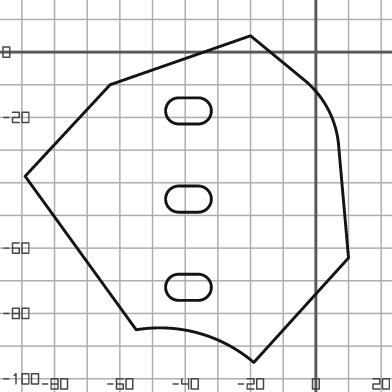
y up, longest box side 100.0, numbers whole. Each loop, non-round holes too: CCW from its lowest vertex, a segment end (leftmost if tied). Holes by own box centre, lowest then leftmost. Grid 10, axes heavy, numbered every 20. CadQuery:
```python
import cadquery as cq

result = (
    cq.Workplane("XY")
    .moveTo(-19.0, -95.0)
    .lineTo(10.0, -63.0)
    .lineTo(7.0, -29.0)
    .threePointArc((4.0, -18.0), (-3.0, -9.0))
    .lineTo(-20.0, 5.0)
    .lineTo(-63.0, -10.0)
    .lineTo(-89.0, -38.0)
    .lineTo(-55.0, -85.0)
    .threePointArc((-36.0, -86.0), (-19.0, -95.0))
    .close()
    .moveTo(-42.0, -76.0)
    .lineTo(-36.0, -76.0)
    .threePointArc((-32.0, -72.0), (-36.0, -68.0))
    .lineTo(-42.0, -68.0)
    .threePointArc((-46.0, -72.0), (-42.0, -76.0))
    .close()
    .moveTo(-42.0, -49.0)
    .lineTo(-36.0, -49.0)
    .threePointArc((-32.0, -45.0), (-36.0, -41.0))
    .lineTo(-42.0, -41.0)
    .threePointArc((-46.0, -45.0), (-42.0, -49.0))
    .close()
    .moveTo(-42.0, -22.0)
    .lineTo(-36.0, -22.0)
    .threePointArc((-32.0, -18.0), (-36.0, -14.0))
    .lineTo(-42.0, -14.0)
    .threePointArc((-46.0, -18.0), (-42.0, -22.0))
    .close()
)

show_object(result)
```